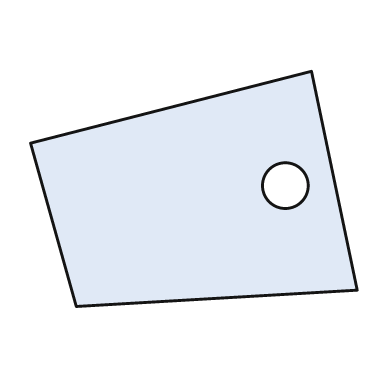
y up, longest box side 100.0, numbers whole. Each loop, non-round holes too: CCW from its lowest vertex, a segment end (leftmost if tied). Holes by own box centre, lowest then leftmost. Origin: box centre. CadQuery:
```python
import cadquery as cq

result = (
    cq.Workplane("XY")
    .moveTo(-36.0, -36.0)
    .lineTo(50.0, -31.0)
    .lineTo(36.0, 36.0)
    .lineTo(-50.0, 14.0)
    .close()
    .moveTo(28.0, 1.0)
    .circle(7.0)
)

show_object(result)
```